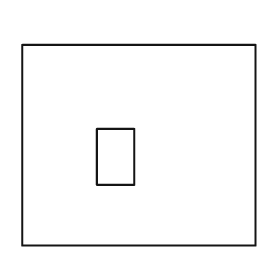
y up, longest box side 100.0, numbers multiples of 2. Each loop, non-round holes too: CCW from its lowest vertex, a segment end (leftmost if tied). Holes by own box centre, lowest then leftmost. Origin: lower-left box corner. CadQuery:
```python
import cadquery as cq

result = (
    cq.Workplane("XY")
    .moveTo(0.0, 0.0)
    .lineTo(100.0, 0.0)
    .lineTo(100.0, 86.0)
    .lineTo(0.0, 86.0)
    .close()
    .moveTo(32.0, 26.0)
    .lineTo(48.0, 26.0)
    .lineTo(48.0, 50.0)
    .lineTo(32.0, 50.0)
    .close()
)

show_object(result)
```